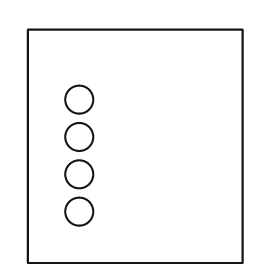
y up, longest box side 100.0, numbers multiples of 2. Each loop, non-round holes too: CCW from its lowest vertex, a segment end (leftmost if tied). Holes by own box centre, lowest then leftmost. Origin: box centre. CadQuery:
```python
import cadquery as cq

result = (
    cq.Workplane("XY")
    .moveTo(-46.0, -50.0)
    .lineTo(46.0, -50.0)
    .lineTo(46.0, 50.0)
    .lineTo(-46.0, 50.0)
    .close()
    .moveTo(-24.0, -28.0)
    .circle(6.0)
    .moveTo(-24.0, -12.0)
    .circle(6.0)
    .moveTo(-24.0, 4.0)
    .circle(6.0)
    .moveTo(-24.0, 20.0)
    .circle(6.0)
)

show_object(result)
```